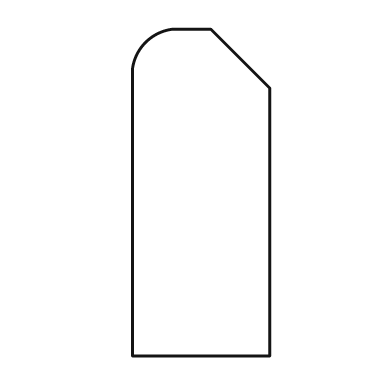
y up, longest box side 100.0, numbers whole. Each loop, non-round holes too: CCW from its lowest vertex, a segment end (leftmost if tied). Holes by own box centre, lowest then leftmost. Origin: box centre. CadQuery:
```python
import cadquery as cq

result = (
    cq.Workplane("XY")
    .moveTo(-21.0, -50.0)
    .lineTo(21.0, -50.0)
    .lineTo(21.0, 32.0)
    .lineTo(3.0, 50.0)
    .lineTo(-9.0, 50.0)
    .threePointArc((-17.0, 46.0), (-21.0, 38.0))
    .close()
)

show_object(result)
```